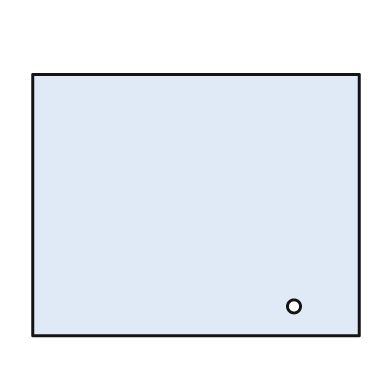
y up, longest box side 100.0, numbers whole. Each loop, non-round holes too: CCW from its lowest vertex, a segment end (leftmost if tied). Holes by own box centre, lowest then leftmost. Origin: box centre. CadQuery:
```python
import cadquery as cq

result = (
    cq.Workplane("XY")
    .moveTo(-50.0, -40.0)
    .lineTo(50.0, -40.0)
    .lineTo(50.0, 40.0)
    .lineTo(-50.0, 40.0)
    .close()
    .moveTo(30.0, -31.0)
    .circle(2.0)
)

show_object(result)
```